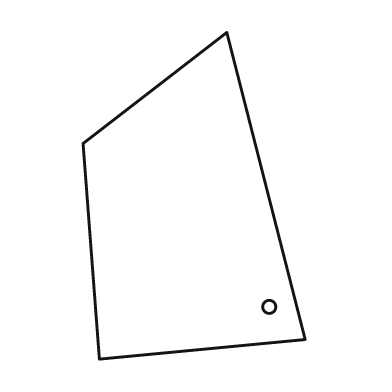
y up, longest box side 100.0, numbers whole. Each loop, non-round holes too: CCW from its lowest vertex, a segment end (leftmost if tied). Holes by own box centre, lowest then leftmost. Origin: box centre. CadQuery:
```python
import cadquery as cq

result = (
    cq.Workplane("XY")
    .moveTo(-29.0, -50.0)
    .lineTo(34.0, -44.0)
    .lineTo(10.0, 50.0)
    .lineTo(-34.0, 16.0)
    .close()
    .moveTo(23.0, -34.0)
    .circle(2.0)
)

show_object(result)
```